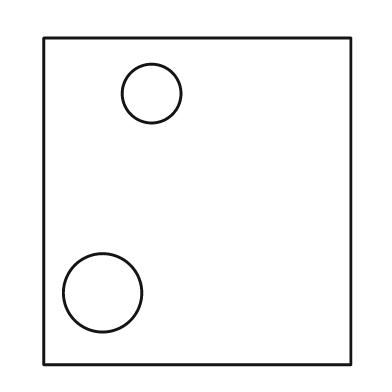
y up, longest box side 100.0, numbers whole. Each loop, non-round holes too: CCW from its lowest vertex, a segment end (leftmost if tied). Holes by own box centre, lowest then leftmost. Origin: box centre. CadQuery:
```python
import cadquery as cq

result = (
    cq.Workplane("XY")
    .moveTo(-47.0, -50.0)
    .lineTo(47.0, -50.0)
    .lineTo(47.0, 50.0)
    .lineTo(-47.0, 50.0)
    .close()
    .moveTo(-29.0, -28.0)
    .circle(12.0)
    .moveTo(-14.0, 33.0)
    .circle(9.0)
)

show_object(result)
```